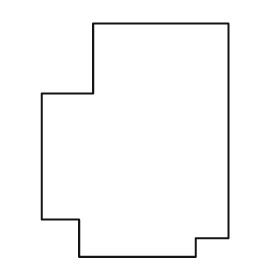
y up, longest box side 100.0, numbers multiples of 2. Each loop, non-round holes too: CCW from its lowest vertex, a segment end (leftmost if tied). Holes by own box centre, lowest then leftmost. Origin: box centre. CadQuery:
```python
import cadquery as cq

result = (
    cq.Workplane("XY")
    .moveTo(-24.0, -50.0)
    .lineTo(26.0, -50.0)
    .lineTo(26.0, -42.0)
    .lineTo(40.0, -42.0)
    .lineTo(40.0, 50.0)
    .lineTo(-18.0, 50.0)
    .lineTo(-18.0, 20.0)
    .lineTo(-40.0, 20.0)
    .lineTo(-40.0, -34.0)
    .lineTo(-24.0, -34.0)
    .close()
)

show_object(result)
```